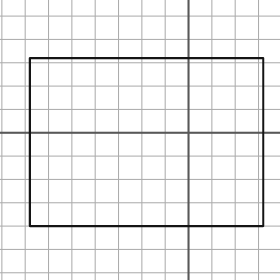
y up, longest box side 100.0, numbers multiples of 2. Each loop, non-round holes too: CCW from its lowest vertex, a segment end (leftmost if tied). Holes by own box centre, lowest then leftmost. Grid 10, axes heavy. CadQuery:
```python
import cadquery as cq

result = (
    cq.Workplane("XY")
    .moveTo(-68.0, -40.0)
    .lineTo(32.0, -40.0)
    .lineTo(32.0, 32.0)
    .lineTo(-68.0, 32.0)
    .close()
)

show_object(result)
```